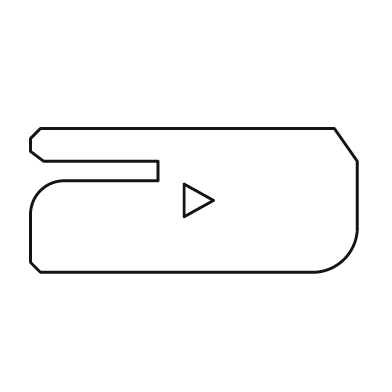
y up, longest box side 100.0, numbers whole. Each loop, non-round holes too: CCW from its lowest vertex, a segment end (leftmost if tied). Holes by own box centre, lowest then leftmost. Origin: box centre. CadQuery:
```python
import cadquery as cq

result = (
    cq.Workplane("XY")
    .moveTo(-47.0, -22.0)
    .lineTo(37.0, -22.0)
    .threePointArc((46.0, -18.0), (50.0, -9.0))
    .lineTo(50.0, 12.0)
    .lineTo(43.0, 22.0)
    .lineTo(-47.0, 22.0)
    .lineTo(-50.0, 19.0)
    .lineTo(-50.0, 15.0)
    .lineTo(-46.0, 12.0)
    .lineTo(-11.0, 12.0)
    .lineTo(-11.0, 6.0)
    .lineTo(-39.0, 6.0)
    .threePointArc((-47.0, 3.0), (-50.0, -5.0))
    .lineTo(-50.0, -19.0)
    .close()
    .moveTo(-3.0, -5.0)
    .lineTo(6.0, 0.0)
    .lineTo(-3.0, 5.0)
    .close()
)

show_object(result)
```